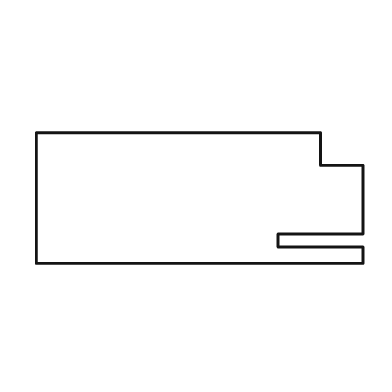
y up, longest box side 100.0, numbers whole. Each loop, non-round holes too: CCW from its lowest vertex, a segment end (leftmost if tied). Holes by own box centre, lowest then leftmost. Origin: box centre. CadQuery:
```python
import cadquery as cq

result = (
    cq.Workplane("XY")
    .moveTo(-50.0, -20.0)
    .lineTo(50.0, -20.0)
    .lineTo(50.0, -15.0)
    .lineTo(24.0, -15.0)
    .lineTo(24.0, -11.0)
    .lineTo(50.0, -11.0)
    .lineTo(50.0, 10.0)
    .lineTo(37.0, 10.0)
    .lineTo(37.0, 20.0)
    .lineTo(-50.0, 20.0)
    .close()
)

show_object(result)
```